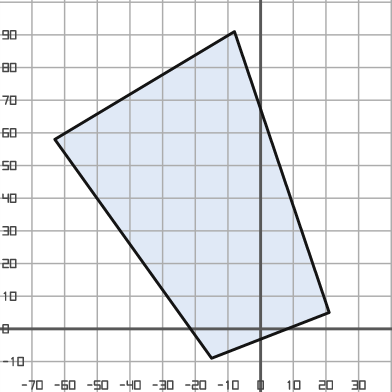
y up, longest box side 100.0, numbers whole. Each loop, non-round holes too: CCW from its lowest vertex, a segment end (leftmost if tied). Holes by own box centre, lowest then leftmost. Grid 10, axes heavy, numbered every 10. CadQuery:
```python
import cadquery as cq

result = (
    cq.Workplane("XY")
    .moveTo(-15.0, -9.0)
    .lineTo(21.0, 5.0)
    .lineTo(-8.0, 91.0)
    .lineTo(-63.0, 58.0)
    .close()
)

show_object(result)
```